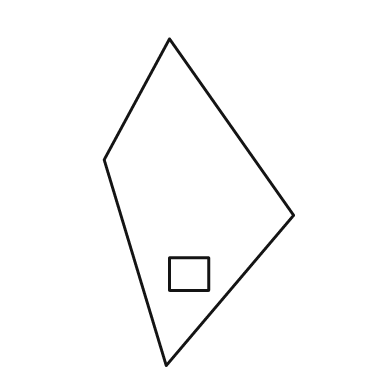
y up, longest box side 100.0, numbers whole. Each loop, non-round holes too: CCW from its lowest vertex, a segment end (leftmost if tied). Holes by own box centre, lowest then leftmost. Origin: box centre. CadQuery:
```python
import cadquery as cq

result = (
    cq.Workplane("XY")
    .moveTo(-10.0, -50.0)
    .lineTo(29.0, -4.0)
    .lineTo(-9.0, 50.0)
    .lineTo(-29.0, 13.0)
    .close()
    .moveTo(-9.0, -27.0)
    .lineTo(3.0, -27.0)
    .lineTo(3.0, -17.0)
    .lineTo(-9.0, -17.0)
    .close()
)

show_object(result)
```